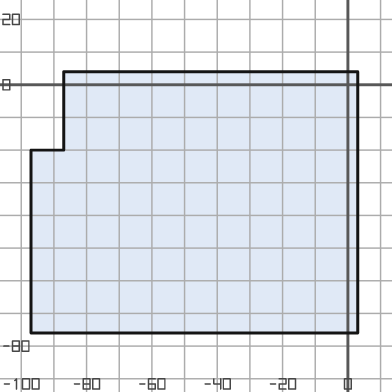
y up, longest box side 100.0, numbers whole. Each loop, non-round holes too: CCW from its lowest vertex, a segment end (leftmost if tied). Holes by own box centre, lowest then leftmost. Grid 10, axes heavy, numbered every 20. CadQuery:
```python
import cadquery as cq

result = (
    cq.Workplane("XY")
    .moveTo(-97.0, -76.0)
    .lineTo(3.0, -76.0)
    .lineTo(3.0, 4.0)
    .lineTo(-87.0, 4.0)
    .lineTo(-87.0, -20.0)
    .lineTo(-97.0, -20.0)
    .close()
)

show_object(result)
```